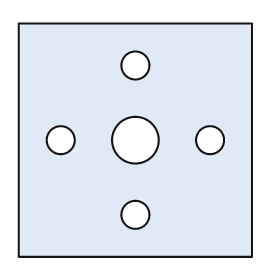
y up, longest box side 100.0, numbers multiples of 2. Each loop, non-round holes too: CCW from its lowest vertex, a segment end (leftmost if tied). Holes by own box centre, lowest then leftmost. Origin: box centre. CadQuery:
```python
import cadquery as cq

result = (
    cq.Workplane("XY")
    .moveTo(-50.0, -50.0)
    .lineTo(50.0, -50.0)
    .lineTo(50.0, 50.0)
    .lineTo(-50.0, 50.0)
    .close()
    .moveTo(0.0, -32.0)
    .circle(6.0)
    .moveTo(-32.0, 0.0)
    .circle(6.0)
    .moveTo(0.0, 0.0)
    .circle(10.0)
    .moveTo(32.0, 0.0)
    .circle(6.0)
    .moveTo(0.0, 32.0)
    .circle(6.0)
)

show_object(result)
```